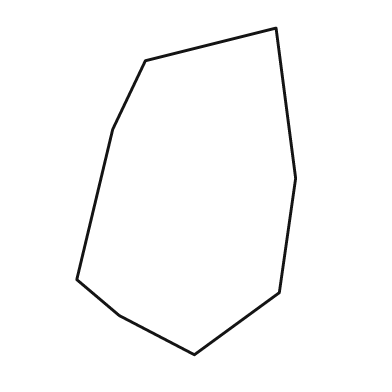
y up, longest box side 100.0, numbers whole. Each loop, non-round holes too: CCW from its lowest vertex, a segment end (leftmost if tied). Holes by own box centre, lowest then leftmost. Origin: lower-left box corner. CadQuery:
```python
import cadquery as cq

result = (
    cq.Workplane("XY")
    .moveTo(36.0, 0.0)
    .lineTo(62.0, 19.0)
    .lineTo(67.0, 54.0)
    .lineTo(61.0, 100.0)
    .lineTo(21.0, 90.0)
    .lineTo(11.0, 69.0)
    .lineTo(0.0, 23.0)
    .lineTo(13.0, 12.0)
    .close()
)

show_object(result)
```